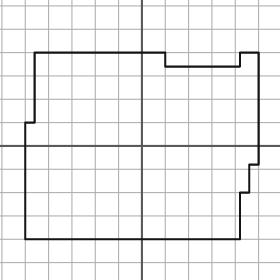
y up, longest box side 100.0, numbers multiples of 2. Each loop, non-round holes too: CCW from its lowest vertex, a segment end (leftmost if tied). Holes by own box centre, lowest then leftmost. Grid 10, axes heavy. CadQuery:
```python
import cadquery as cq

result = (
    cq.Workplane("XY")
    .moveTo(-50.0, -40.0)
    .lineTo(42.0, -40.0)
    .lineTo(42.0, -20.0)
    .lineTo(46.0, -20.0)
    .lineTo(46.0, -8.0)
    .lineTo(50.0, -8.0)
    .lineTo(50.0, 40.0)
    .lineTo(42.0, 40.0)
    .lineTo(42.0, 34.0)
    .lineTo(10.0, 34.0)
    .lineTo(10.0, 40.0)
    .lineTo(-46.0, 40.0)
    .lineTo(-46.0, 10.0)
    .lineTo(-50.0, 10.0)
    .close()
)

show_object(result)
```